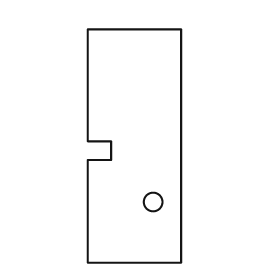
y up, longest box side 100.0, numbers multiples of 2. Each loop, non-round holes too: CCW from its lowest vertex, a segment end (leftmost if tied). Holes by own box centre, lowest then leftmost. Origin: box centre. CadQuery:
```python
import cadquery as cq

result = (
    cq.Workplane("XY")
    .moveTo(-20.0, -50.0)
    .lineTo(20.0, -50.0)
    .lineTo(20.0, 50.0)
    .lineTo(-20.0, 50.0)
    .lineTo(-20.0, 2.0)
    .lineTo(-10.0, 2.0)
    .lineTo(-10.0, -6.0)
    .lineTo(-20.0, -6.0)
    .close()
    .moveTo(8.0, -24.0)
    .circle(4.0)
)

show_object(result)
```